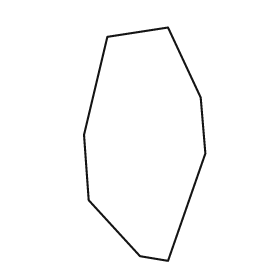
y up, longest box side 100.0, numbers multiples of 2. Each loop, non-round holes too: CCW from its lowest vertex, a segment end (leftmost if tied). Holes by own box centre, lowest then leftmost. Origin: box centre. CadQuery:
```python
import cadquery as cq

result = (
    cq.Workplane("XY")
    .moveTo(10.0, -50.0)
    .lineTo(26.0, -4.0)
    .lineTo(24.0, 20.0)
    .lineTo(10.0, 50.0)
    .lineTo(-16.0, 46.0)
    .lineTo(-26.0, 4.0)
    .lineTo(-24.0, -24.0)
    .lineTo(-2.0, -48.0)
    .close()
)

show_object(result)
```